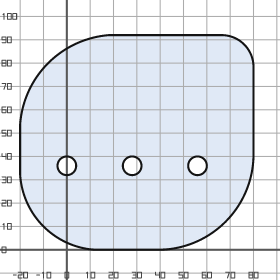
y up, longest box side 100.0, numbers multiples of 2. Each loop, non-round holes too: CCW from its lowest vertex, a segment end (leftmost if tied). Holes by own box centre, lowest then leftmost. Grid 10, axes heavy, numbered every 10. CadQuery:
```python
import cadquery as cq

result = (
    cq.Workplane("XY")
    .moveTo(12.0, 0.0)
    .lineTo(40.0, 0.0)
    .threePointArc((68.0, 12.0), (80.0, 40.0))
    .lineTo(80.0, 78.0)
    .threePointArc((76.0, 88.0), (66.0, 92.0))
    .lineTo(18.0, 92.0)
    .threePointArc((-8.0, 80.0), (-20.0, 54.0))
    .lineTo(-20.0, 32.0)
    .threePointArc((-10.0, 10.0), (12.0, 0.0))
    .close()
    .moveTo(0.0, 36.0)
    .circle(4.0)
    .moveTo(28.0, 36.0)
    .circle(4.0)
    .moveTo(56.0, 36.0)
    .circle(4.0)
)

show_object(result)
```